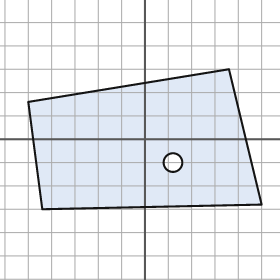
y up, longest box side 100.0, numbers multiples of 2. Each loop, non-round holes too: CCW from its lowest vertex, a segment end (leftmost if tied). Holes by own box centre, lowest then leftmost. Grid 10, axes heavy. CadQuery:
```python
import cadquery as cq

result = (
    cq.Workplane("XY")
    .moveTo(-44.0, -30.0)
    .lineTo(50.0, -28.0)
    .lineTo(36.0, 30.0)
    .lineTo(-50.0, 16.0)
    .close()
    .moveTo(12.0, -10.0)
    .circle(4.0)
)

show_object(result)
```